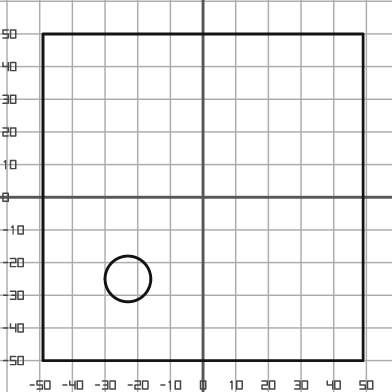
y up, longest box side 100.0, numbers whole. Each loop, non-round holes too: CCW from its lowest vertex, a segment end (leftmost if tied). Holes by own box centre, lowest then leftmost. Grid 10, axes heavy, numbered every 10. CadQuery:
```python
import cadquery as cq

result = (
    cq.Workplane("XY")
    .moveTo(-49.0, -50.0)
    .lineTo(49.0, -50.0)
    .lineTo(49.0, 50.0)
    .lineTo(-49.0, 50.0)
    .close()
    .moveTo(-23.0, -25.0)
    .circle(7.0)
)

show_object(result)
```